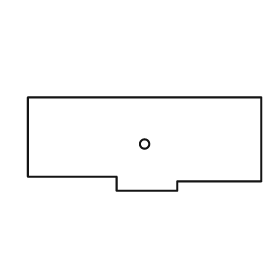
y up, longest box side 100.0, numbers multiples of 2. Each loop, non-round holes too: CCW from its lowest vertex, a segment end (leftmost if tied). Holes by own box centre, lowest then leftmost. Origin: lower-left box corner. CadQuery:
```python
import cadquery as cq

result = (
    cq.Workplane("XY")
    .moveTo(38.0, 0.0)
    .lineTo(64.0, 0.0)
    .lineTo(64.0, 4.0)
    .lineTo(100.0, 4.0)
    .lineTo(100.0, 40.0)
    .lineTo(0.0, 40.0)
    .lineTo(0.0, 6.0)
    .lineTo(38.0, 6.0)
    .close()
    .moveTo(50.0, 20.0)
    .circle(2.0)
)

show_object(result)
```